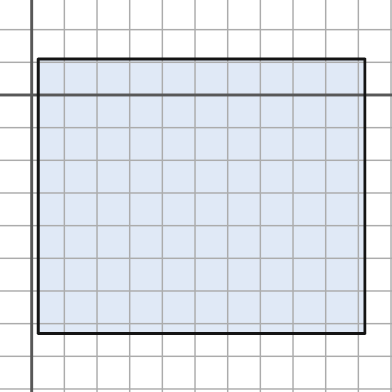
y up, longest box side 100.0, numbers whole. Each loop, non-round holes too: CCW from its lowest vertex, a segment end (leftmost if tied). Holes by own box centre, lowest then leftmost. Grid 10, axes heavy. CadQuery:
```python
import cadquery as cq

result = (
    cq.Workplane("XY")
    .moveTo(2.0, -73.0)
    .lineTo(102.0, -73.0)
    .lineTo(102.0, 11.0)
    .lineTo(2.0, 11.0)
    .close()
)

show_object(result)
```